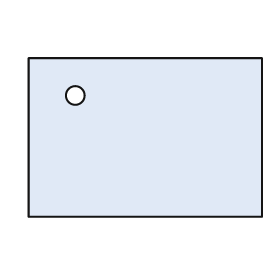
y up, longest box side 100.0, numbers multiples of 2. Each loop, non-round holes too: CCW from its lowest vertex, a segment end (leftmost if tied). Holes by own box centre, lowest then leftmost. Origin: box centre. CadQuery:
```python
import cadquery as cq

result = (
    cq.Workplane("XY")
    .moveTo(-50.0, -34.0)
    .lineTo(50.0, -34.0)
    .lineTo(50.0, 34.0)
    .lineTo(-50.0, 34.0)
    .close()
    .moveTo(-30.0, 18.0)
    .circle(4.0)
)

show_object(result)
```